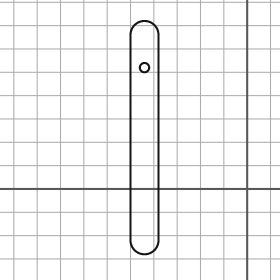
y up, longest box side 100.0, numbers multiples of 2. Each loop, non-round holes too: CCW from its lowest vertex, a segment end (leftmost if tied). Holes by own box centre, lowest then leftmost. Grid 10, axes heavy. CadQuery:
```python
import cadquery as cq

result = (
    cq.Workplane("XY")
    .moveTo(-50.0, -22.0)
    .threePointArc((-44.0, -28.0), (-38.0, -22.0))
    .lineTo(-38.0, 66.0)
    .threePointArc((-44.0, 72.0), (-50.0, 66.0))
    .close()
    .moveTo(-44.0, 52.0)
    .circle(2.0)
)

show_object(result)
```